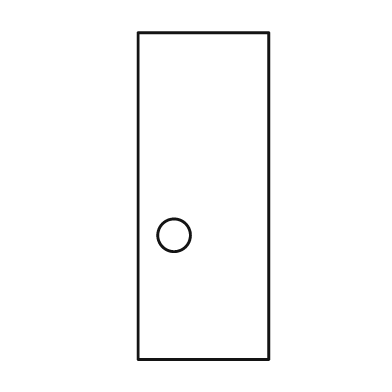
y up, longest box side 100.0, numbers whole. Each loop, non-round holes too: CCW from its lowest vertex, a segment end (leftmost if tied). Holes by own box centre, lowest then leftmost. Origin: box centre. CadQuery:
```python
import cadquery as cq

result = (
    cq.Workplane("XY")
    .moveTo(-20.0, -50.0)
    .lineTo(20.0, -50.0)
    .lineTo(20.0, 50.0)
    .lineTo(-20.0, 50.0)
    .close()
    .moveTo(-9.0, -12.0)
    .circle(5.0)
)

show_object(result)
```